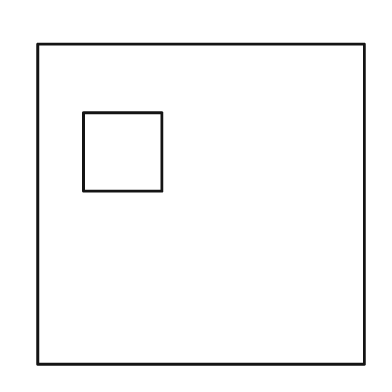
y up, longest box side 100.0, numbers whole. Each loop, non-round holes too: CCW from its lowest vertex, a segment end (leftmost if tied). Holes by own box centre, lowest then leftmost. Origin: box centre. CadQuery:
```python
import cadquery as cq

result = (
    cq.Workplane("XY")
    .moveTo(-50.0, -49.0)
    .lineTo(50.0, -49.0)
    .lineTo(50.0, 49.0)
    .lineTo(-50.0, 49.0)
    .close()
    .moveTo(-36.0, 4.0)
    .lineTo(-12.0, 4.0)
    .lineTo(-12.0, 28.0)
    .lineTo(-36.0, 28.0)
    .close()
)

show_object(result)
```